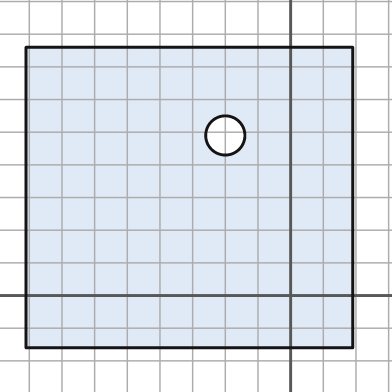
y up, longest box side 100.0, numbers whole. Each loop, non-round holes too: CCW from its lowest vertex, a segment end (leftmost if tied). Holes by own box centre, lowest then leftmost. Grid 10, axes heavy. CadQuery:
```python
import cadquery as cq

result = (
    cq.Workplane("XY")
    .moveTo(-81.0, -16.0)
    .lineTo(19.0, -16.0)
    .lineTo(19.0, 76.0)
    .lineTo(-81.0, 76.0)
    .close()
    .moveTo(-20.0, 49.0)
    .circle(6.0)
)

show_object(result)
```